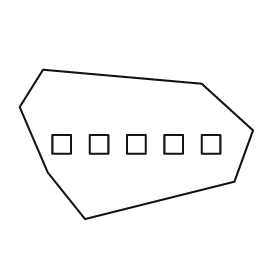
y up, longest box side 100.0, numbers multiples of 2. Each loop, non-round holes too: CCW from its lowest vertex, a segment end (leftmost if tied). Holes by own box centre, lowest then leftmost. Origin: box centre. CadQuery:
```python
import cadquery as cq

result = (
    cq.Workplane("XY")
    .moveTo(-22.0, -32.0)
    .lineTo(42.0, -16.0)
    .lineTo(50.0, 6.0)
    .lineTo(28.0, 26.0)
    .lineTo(-40.0, 32.0)
    .lineTo(-50.0, 16.0)
    .lineTo(-38.0, -12.0)
    .close()
    .moveTo(-36.0, -4.0)
    .lineTo(-28.0, -4.0)
    .lineTo(-28.0, 4.0)
    .lineTo(-36.0, 4.0)
    .close()
    .moveTo(-20.0, -4.0)
    .lineTo(-12.0, -4.0)
    .lineTo(-12.0, 4.0)
    .lineTo(-20.0, 4.0)
    .close()
    .moveTo(-4.0, -4.0)
    .lineTo(4.0, -4.0)
    .lineTo(4.0, 4.0)
    .lineTo(-4.0, 4.0)
    .close()
    .moveTo(12.0, -4.0)
    .lineTo(20.0, -4.0)
    .lineTo(20.0, 4.0)
    .lineTo(12.0, 4.0)
    .close()
    .moveTo(28.0, -4.0)
    .lineTo(36.0, -4.0)
    .lineTo(36.0, 4.0)
    .lineTo(28.0, 4.0)
    .close()
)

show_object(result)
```